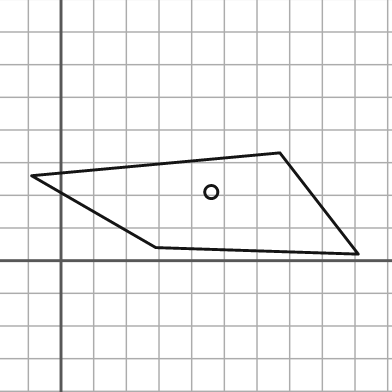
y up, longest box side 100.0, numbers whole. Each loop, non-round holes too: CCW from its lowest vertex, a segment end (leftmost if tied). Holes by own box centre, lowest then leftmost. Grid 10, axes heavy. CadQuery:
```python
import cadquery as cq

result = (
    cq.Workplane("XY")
    .moveTo(91.0, 2.0)
    .lineTo(67.0, 33.0)
    .lineTo(-9.0, 26.0)
    .lineTo(29.0, 4.0)
    .close()
    .moveTo(46.0, 21.0)
    .circle(2.0)
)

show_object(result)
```